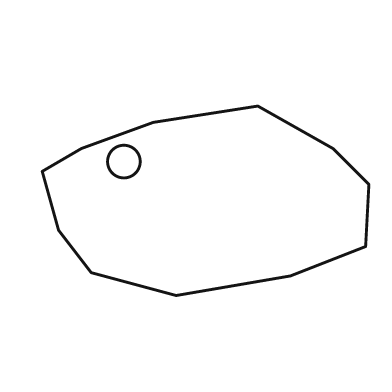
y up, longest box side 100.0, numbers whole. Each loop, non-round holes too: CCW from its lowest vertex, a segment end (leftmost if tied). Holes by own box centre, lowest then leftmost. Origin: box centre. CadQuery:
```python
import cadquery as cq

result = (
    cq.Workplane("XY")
    .moveTo(-9.0, -29.0)
    .lineTo(26.0, -23.0)
    .lineTo(49.0, -14.0)
    .lineTo(50.0, 5.0)
    .lineTo(39.0, 16.0)
    .lineTo(16.0, 29.0)
    .lineTo(-16.0, 24.0)
    .lineTo(-38.0, 16.0)
    .lineTo(-50.0, 9.0)
    .lineTo(-45.0, -9.0)
    .lineTo(-35.0, -22.0)
    .close()
    .moveTo(-25.0, 12.0)
    .circle(5.0)
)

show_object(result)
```